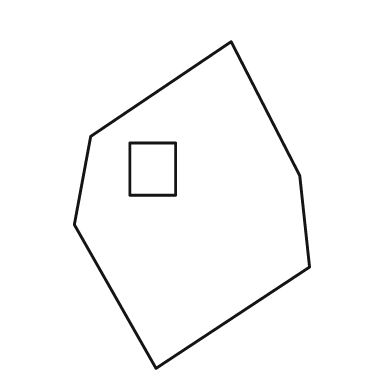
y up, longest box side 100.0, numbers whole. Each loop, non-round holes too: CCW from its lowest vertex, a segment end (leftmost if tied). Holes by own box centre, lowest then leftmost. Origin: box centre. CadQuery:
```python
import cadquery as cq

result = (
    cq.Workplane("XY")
    .moveTo(-11.0, -50.0)
    .lineTo(36.0, -19.0)
    .lineTo(33.0, 9.0)
    .lineTo(12.0, 50.0)
    .lineTo(-31.0, 21.0)
    .lineTo(-36.0, -6.0)
    .close()
    .moveTo(-19.0, 3.0)
    .lineTo(-5.0, 3.0)
    .lineTo(-5.0, 19.0)
    .lineTo(-19.0, 19.0)
    .close()
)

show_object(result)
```